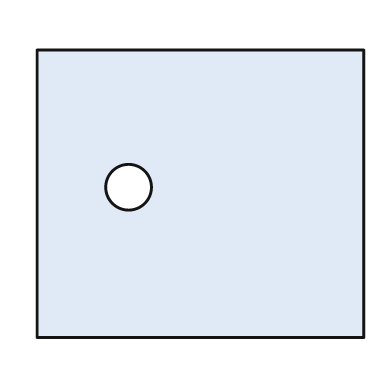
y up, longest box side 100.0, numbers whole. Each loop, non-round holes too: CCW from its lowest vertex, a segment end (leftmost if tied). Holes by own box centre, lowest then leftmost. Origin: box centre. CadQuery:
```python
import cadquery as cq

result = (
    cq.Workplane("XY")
    .moveTo(-50.0, -44.0)
    .lineTo(50.0, -44.0)
    .lineTo(50.0, 44.0)
    .lineTo(-50.0, 44.0)
    .close()
    .moveTo(-22.0, 2.0)
    .circle(7.0)
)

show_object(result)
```